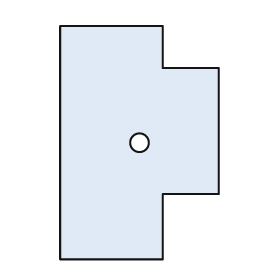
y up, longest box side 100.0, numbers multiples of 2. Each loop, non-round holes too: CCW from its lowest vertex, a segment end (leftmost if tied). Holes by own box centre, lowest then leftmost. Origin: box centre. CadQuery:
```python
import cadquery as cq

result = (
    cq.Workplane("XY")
    .moveTo(-34.0, -50.0)
    .lineTo(10.0, -50.0)
    .lineTo(10.0, -22.0)
    .lineTo(34.0, -22.0)
    .lineTo(34.0, 32.0)
    .lineTo(10.0, 32.0)
    .lineTo(10.0, 50.0)
    .lineTo(-34.0, 50.0)
    .close()
    .moveTo(0.0, 0.0)
    .circle(4.0)
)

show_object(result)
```